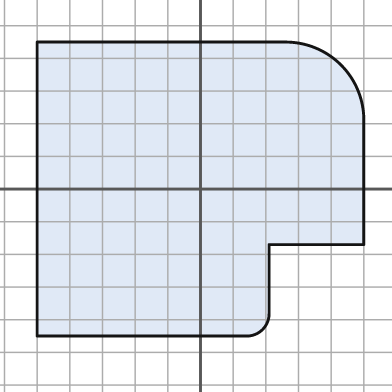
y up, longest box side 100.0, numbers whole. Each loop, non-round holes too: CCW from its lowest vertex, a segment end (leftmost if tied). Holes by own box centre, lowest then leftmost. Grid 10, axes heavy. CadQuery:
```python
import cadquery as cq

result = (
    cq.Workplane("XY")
    .moveTo(-50.0, -45.0)
    .lineTo(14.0, -45.0)
    .threePointArc((19.0, -43.0), (21.0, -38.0))
    .lineTo(21.0, -17.0)
    .lineTo(50.0, -17.0)
    .lineTo(50.0, 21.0)
    .threePointArc((43.0, 38.0), (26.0, 45.0))
    .lineTo(-50.0, 45.0)
    .close()
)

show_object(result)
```